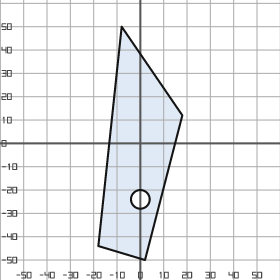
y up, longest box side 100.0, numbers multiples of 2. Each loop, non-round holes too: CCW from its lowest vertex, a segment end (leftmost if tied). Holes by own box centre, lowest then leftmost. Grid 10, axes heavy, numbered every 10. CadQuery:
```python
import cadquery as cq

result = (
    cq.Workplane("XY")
    .moveTo(2.0, -50.0)
    .lineTo(18.0, 12.0)
    .lineTo(-8.0, 50.0)
    .lineTo(-18.0, -44.0)
    .close()
    .moveTo(0.0, -24.0)
    .circle(4.0)
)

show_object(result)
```